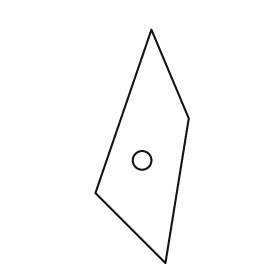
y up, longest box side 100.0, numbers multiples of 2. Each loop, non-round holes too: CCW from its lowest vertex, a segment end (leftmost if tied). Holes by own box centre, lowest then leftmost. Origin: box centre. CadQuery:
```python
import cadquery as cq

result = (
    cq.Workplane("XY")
    .moveTo(10.0, -50.0)
    .lineTo(20.0, 12.0)
    .lineTo(4.0, 50.0)
    .lineTo(-20.0, -20.0)
    .close()
    .moveTo(0.0, -6.0)
    .circle(4.0)
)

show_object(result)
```